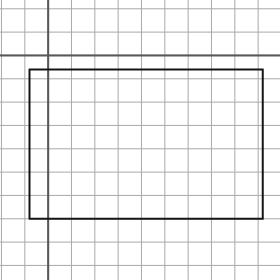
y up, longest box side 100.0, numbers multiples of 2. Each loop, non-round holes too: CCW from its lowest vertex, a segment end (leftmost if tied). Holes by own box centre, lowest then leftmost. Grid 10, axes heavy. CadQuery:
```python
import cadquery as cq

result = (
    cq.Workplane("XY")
    .moveTo(-8.0, -70.0)
    .lineTo(92.0, -70.0)
    .lineTo(92.0, -6.0)
    .lineTo(-8.0, -6.0)
    .close()
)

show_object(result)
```